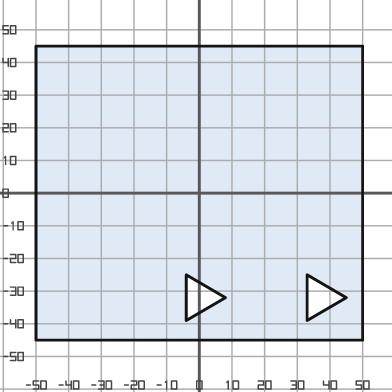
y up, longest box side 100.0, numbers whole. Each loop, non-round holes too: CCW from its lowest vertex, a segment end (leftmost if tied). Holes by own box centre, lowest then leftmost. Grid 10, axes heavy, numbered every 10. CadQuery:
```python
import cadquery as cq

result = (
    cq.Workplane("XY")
    .moveTo(-50.0, -45.0)
    .lineTo(50.0, -45.0)
    .lineTo(50.0, 45.0)
    .lineTo(-50.0, 45.0)
    .close()
    .moveTo(-4.0, -39.0)
    .lineTo(8.0, -32.0)
    .lineTo(-4.0, -25.0)
    .close()
    .moveTo(33.0, -39.0)
    .lineTo(45.0, -32.0)
    .lineTo(33.0, -25.0)
    .close()
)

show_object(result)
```